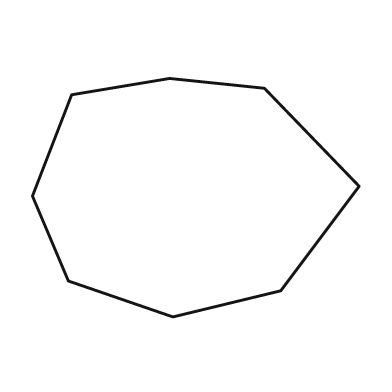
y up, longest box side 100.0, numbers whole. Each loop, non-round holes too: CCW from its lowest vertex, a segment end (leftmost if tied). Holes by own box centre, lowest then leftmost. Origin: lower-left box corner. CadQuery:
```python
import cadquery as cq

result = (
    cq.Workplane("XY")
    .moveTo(43.0, 0.0)
    .lineTo(76.0, 8.0)
    .lineTo(100.0, 40.0)
    .lineTo(71.0, 70.0)
    .lineTo(42.0, 73.0)
    .lineTo(12.0, 68.0)
    .lineTo(0.0, 37.0)
    .lineTo(11.0, 11.0)
    .close()
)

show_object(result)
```